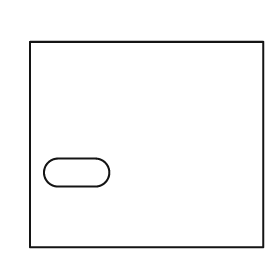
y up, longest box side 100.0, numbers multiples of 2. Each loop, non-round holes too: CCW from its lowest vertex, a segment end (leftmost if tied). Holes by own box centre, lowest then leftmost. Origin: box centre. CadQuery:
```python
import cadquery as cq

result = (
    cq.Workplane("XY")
    .moveTo(-50.0, -44.0)
    .lineTo(50.0, -44.0)
    .lineTo(50.0, 44.0)
    .lineTo(-50.0, 44.0)
    .close()
    .moveTo(-38.0, -18.0)
    .lineTo(-22.0, -18.0)
    .threePointArc((-16.0, -12.0), (-22.0, -6.0))
    .lineTo(-38.0, -6.0)
    .threePointArc((-44.0, -12.0), (-38.0, -18.0))
    .close()
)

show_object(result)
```